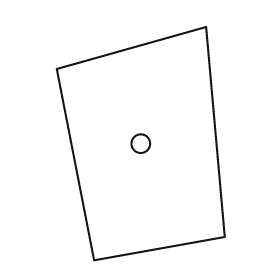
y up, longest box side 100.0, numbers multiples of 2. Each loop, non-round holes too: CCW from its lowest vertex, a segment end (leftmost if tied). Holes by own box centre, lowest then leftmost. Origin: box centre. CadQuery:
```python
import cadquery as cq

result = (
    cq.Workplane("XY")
    .moveTo(-20.0, -50.0)
    .lineTo(36.0, -40.0)
    .lineTo(28.0, 50.0)
    .lineTo(-36.0, 32.0)
    .close()
    .moveTo(0.0, 0.0)
    .circle(4.0)
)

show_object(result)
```